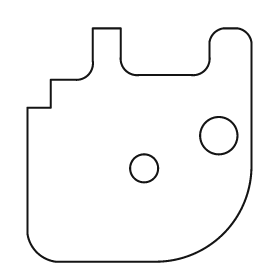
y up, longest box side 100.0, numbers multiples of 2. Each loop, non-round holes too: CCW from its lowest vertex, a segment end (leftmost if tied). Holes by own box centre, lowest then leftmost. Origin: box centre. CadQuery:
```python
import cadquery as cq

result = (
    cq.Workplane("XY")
    .moveTo(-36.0, -50.0)
    .lineTo(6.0, -50.0)
    .threePointArc((36.0, -38.0), (48.0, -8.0))
    .lineTo(48.0, 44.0)
    .threePointArc((46.0, 48.0), (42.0, 50.0))
    .lineTo(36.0, 50.0)
    .threePointArc((32.0, 48.0), (30.0, 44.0))
    .lineTo(30.0, 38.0)
    .threePointArc((28.0, 32.0), (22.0, 30.0))
    .lineTo(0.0, 30.0)
    .threePointArc((-6.0, 32.0), (-8.0, 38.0))
    .lineTo(-8.0, 50.0)
    .lineTo(-20.0, 50.0)
    .lineTo(-20.0, 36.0)
    .threePointArc((-22.0, 30.0), (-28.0, 28.0))
    .lineTo(-38.0, 28.0)
    .lineTo(-38.0, 16.0)
    .lineTo(-48.0, 16.0)
    .lineTo(-48.0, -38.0)
    .threePointArc((-44.0, -46.0), (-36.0, -50.0))
    .close()
    .moveTo(2.0, -10.0)
    .circle(6.0)
    .moveTo(34.0, 4.0)
    .circle(8.0)
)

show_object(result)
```